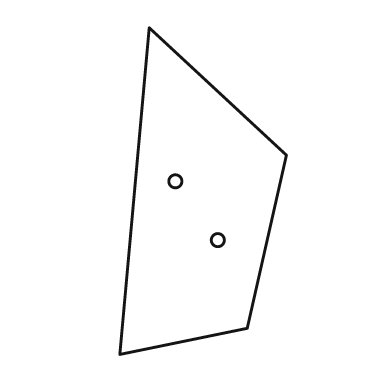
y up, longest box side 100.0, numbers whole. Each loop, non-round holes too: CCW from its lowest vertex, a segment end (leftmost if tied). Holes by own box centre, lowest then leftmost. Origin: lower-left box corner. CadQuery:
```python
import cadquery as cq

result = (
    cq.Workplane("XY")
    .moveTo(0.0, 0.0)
    .lineTo(39.0, 8.0)
    .lineTo(51.0, 61.0)
    .lineTo(9.0, 100.0)
    .close()
    .moveTo(30.0, 35.0)
    .circle(2.0)
    .moveTo(17.0, 53.0)
    .circle(2.0)
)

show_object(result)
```